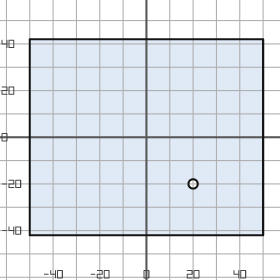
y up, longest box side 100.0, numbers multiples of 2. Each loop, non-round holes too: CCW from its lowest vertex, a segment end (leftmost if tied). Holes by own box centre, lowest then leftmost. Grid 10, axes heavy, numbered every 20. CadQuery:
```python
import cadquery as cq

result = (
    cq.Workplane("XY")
    .moveTo(-50.0, -42.0)
    .lineTo(50.0, -42.0)
    .lineTo(50.0, 42.0)
    .lineTo(-50.0, 42.0)
    .close()
    .moveTo(20.0, -20.0)
    .circle(2.0)
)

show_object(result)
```